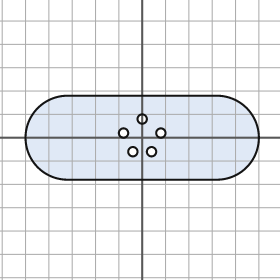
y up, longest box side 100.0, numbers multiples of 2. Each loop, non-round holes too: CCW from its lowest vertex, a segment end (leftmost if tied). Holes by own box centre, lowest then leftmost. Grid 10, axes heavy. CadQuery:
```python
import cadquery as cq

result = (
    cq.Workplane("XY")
    .moveTo(-32.0, -18.0)
    .lineTo(32.0, -18.0)
    .threePointArc((50.0, 0.0), (32.0, 18.0))
    .lineTo(-32.0, 18.0)
    .threePointArc((-50.0, 0.0), (-32.0, -18.0))
    .close()
    .moveTo(-4.0, -6.0)
    .circle(2.0)
    .moveTo(4.0, -6.0)
    .circle(2.0)
    .moveTo(-8.0, 2.0)
    .circle(2.0)
    .moveTo(8.0, 2.0)
    .circle(2.0)
    .moveTo(0.0, 8.0)
    .circle(2.0)
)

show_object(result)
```